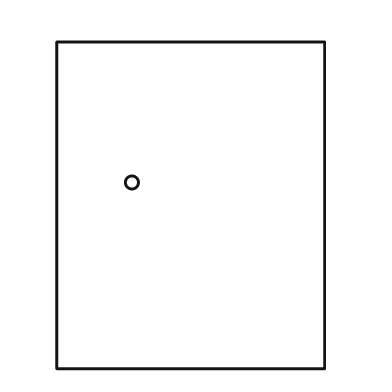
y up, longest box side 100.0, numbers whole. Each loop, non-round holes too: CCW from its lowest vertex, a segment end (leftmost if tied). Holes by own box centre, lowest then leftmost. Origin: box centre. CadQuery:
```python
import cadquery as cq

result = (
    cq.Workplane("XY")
    .moveTo(-41.0, -50.0)
    .lineTo(41.0, -50.0)
    .lineTo(41.0, 50.0)
    .lineTo(-41.0, 50.0)
    .close()
    .moveTo(-18.0, 7.0)
    .circle(2.0)
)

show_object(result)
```